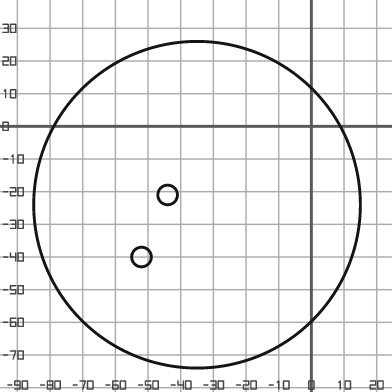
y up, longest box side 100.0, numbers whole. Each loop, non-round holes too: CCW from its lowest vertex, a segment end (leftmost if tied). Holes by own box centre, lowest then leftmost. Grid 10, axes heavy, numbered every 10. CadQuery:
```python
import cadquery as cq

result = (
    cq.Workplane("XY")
    .moveTo(-35.0, -24.0)
    .circle(50.0)
    .moveTo(-52.0, -40.0)
    .circle(3.0)
    .moveTo(-44.0, -21.0)
    .circle(3.0)
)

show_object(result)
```